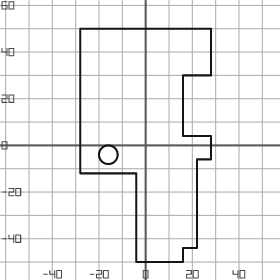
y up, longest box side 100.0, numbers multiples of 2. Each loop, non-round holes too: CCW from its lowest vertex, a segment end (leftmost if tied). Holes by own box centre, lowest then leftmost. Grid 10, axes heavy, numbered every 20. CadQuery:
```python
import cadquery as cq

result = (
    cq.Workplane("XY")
    .moveTo(-4.0, -50.0)
    .lineTo(16.0, -50.0)
    .lineTo(16.0, -44.0)
    .lineTo(22.0, -44.0)
    .lineTo(22.0, -6.0)
    .lineTo(28.0, -6.0)
    .lineTo(28.0, 4.0)
    .lineTo(16.0, 4.0)
    .lineTo(16.0, 30.0)
    .lineTo(28.0, 30.0)
    .lineTo(28.0, 50.0)
    .lineTo(-28.0, 50.0)
    .lineTo(-28.0, -12.0)
    .lineTo(-4.0, -12.0)
    .close()
    .moveTo(-16.0, -4.0)
    .circle(4.0)
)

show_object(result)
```